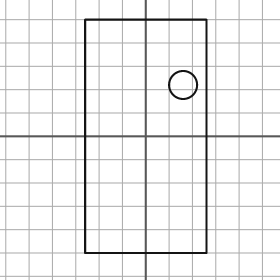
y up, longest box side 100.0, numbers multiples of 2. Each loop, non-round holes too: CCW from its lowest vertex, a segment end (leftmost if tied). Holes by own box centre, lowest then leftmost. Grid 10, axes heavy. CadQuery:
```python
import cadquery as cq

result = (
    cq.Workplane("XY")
    .moveTo(-26.0, -50.0)
    .lineTo(26.0, -50.0)
    .lineTo(26.0, 50.0)
    .lineTo(-26.0, 50.0)
    .close()
    .moveTo(16.0, 22.0)
    .circle(6.0)
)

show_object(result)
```